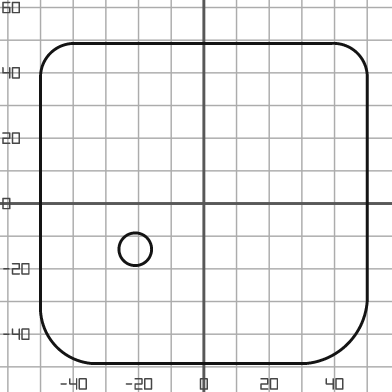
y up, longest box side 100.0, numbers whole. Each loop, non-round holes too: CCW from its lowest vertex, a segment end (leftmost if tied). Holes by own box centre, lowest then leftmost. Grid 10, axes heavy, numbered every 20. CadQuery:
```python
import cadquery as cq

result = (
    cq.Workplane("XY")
    .moveTo(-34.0, -49.0)
    .lineTo(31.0, -49.0)
    .threePointArc((44.0, -43.0), (50.0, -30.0))
    .lineTo(50.0, 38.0)
    .threePointArc((47.0, 46.0), (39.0, 49.0))
    .lineTo(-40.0, 49.0)
    .threePointArc((-47.0, 46.0), (-50.0, 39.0))
    .lineTo(-50.0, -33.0)
    .threePointArc((-45.0, -44.0), (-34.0, -49.0))
    .close()
    .moveTo(-21.0, -14.0)
    .circle(5.0)
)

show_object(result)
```